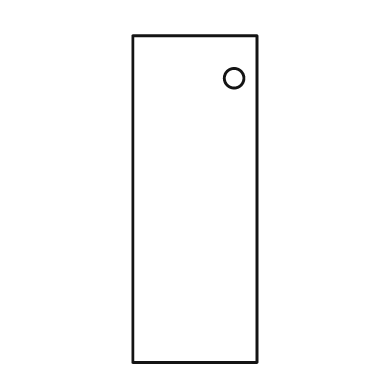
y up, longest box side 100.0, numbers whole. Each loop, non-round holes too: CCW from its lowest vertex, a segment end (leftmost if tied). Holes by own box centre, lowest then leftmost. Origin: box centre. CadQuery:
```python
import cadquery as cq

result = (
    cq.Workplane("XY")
    .moveTo(-19.0, -50.0)
    .lineTo(19.0, -50.0)
    .lineTo(19.0, 50.0)
    .lineTo(-19.0, 50.0)
    .close()
    .moveTo(12.0, 37.0)
    .circle(3.0)
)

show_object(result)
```